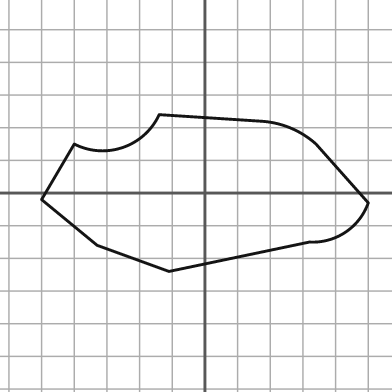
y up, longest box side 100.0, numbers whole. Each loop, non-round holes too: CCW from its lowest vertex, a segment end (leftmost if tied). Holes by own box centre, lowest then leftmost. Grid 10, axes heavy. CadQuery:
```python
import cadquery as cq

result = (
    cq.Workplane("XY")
    .moveTo(-11.0, -24.0)
    .lineTo(32.0, -15.0)
    .threePointArc((43.0, -12.0), (50.0, -3.0))
    .lineTo(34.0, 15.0)
    .threePointArc((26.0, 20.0), (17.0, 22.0))
    .lineTo(-14.0, 24.0)
    .threePointArc((-25.0, 14.0), (-40.0, 15.0))
    .lineTo(-50.0, -2.0)
    .lineTo(-33.0, -16.0)
    .close()
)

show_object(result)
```